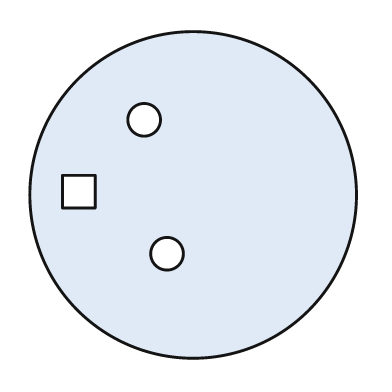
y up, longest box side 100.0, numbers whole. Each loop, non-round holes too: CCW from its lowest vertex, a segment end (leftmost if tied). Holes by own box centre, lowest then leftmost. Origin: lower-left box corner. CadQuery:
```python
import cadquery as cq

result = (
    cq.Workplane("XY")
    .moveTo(50.0, 50.0)
    .circle(50.0)
    .moveTo(42.0, 32.0)
    .circle(5.0)
    .moveTo(10.0, 46.0)
    .lineTo(20.0, 46.0)
    .lineTo(20.0, 56.0)
    .lineTo(10.0, 56.0)
    .close()
    .moveTo(35.0, 73.0)
    .circle(5.0)
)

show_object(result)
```